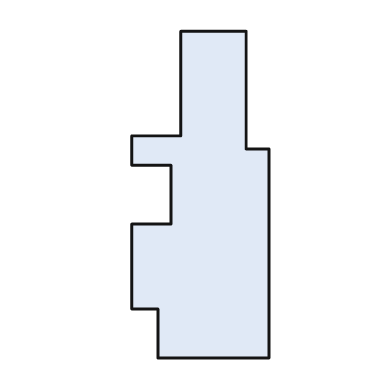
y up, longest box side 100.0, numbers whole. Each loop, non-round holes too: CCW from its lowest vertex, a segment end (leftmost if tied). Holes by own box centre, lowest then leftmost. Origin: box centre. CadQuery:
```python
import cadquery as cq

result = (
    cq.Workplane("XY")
    .moveTo(-13.0, -50.0)
    .lineTo(21.0, -50.0)
    .lineTo(21.0, 14.0)
    .lineTo(14.0, 14.0)
    .lineTo(14.0, 50.0)
    .lineTo(-6.0, 50.0)
    .lineTo(-6.0, 18.0)
    .lineTo(-21.0, 18.0)
    .lineTo(-21.0, 9.0)
    .lineTo(-9.0, 9.0)
    .lineTo(-9.0, -9.0)
    .lineTo(-21.0, -9.0)
    .lineTo(-21.0, -35.0)
    .lineTo(-13.0, -35.0)
    .close()
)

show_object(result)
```